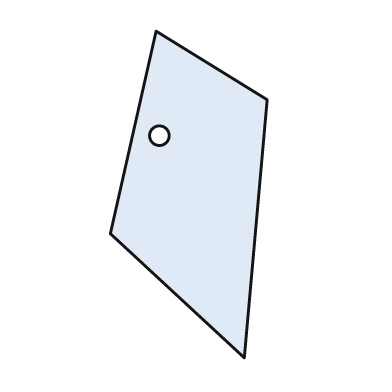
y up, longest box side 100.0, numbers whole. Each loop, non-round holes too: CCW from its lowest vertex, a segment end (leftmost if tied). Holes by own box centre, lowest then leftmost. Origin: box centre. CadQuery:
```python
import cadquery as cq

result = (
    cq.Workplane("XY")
    .moveTo(17.0, -50.0)
    .lineTo(24.0, 29.0)
    .lineTo(-10.0, 50.0)
    .lineTo(-24.0, -12.0)
    .close()
    .moveTo(-9.0, 18.0)
    .circle(3.0)
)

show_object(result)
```